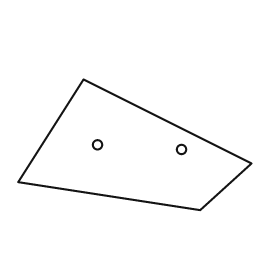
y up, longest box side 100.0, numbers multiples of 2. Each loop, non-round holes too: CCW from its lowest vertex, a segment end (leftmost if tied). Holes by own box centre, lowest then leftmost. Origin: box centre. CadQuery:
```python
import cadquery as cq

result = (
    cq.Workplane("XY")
    .moveTo(28.0, -28.0)
    .lineTo(50.0, -8.0)
    .lineTo(-22.0, 28.0)
    .lineTo(-50.0, -16.0)
    .close()
    .moveTo(20.0, -2.0)
    .circle(2.0)
    .moveTo(-16.0, 0.0)
    .circle(2.0)
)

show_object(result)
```